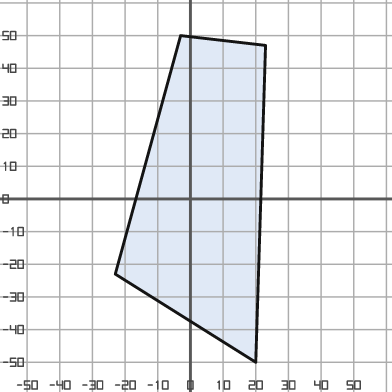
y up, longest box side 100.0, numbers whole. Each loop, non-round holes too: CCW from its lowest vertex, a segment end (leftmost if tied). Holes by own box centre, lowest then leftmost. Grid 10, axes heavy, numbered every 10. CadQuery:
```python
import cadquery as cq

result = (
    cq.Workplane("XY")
    .moveTo(20.0, -50.0)
    .lineTo(23.0, 47.0)
    .lineTo(-3.0, 50.0)
    .lineTo(-23.0, -23.0)
    .close()
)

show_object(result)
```